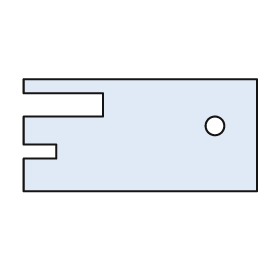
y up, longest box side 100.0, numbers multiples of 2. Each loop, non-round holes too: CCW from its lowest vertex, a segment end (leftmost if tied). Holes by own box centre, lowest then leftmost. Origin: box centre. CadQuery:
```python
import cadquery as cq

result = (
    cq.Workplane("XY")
    .moveTo(-50.0, -24.0)
    .lineTo(50.0, -24.0)
    .lineTo(50.0, 24.0)
    .lineTo(-50.0, 24.0)
    .lineTo(-50.0, 18.0)
    .lineTo(-16.0, 18.0)
    .lineTo(-16.0, 8.0)
    .lineTo(-50.0, 8.0)
    .lineTo(-50.0, -4.0)
    .lineTo(-36.0, -4.0)
    .lineTo(-36.0, -10.0)
    .lineTo(-50.0, -10.0)
    .close()
    .moveTo(32.0, 4.0)
    .circle(4.0)
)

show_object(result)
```